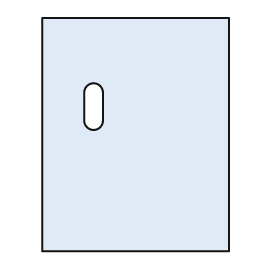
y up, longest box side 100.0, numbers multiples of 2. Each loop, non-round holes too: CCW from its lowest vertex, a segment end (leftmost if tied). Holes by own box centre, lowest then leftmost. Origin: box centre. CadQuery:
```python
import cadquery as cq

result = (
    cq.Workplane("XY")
    .moveTo(-40.0, -50.0)
    .lineTo(40.0, -50.0)
    .lineTo(40.0, 50.0)
    .lineTo(-40.0, 50.0)
    .close()
    .moveTo(-22.0, 6.0)
    .threePointArc((-18.0, 2.0), (-14.0, 6.0))
    .lineTo(-14.0, 18.0)
    .threePointArc((-18.0, 22.0), (-22.0, 18.0))
    .close()
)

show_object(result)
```